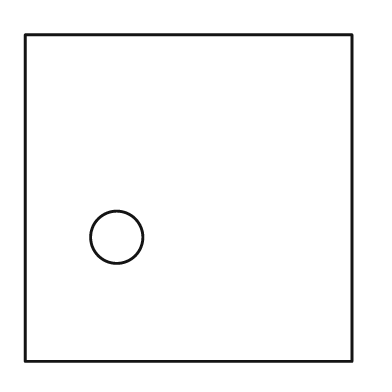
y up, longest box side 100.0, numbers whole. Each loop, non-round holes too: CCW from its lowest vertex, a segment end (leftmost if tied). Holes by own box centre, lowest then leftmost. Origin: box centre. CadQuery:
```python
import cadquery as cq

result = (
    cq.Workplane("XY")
    .moveTo(-50.0, -50.0)
    .lineTo(50.0, -50.0)
    .lineTo(50.0, 50.0)
    .lineTo(-50.0, 50.0)
    .close()
    .moveTo(-22.0, -12.0)
    .circle(8.0)
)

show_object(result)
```